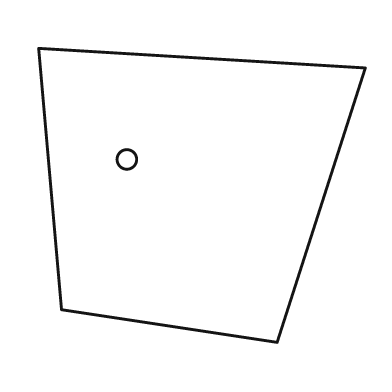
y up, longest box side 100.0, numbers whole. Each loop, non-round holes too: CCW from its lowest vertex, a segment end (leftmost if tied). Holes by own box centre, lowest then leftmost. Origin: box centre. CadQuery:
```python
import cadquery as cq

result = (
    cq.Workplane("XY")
    .moveTo(23.0, -45.0)
    .lineTo(50.0, 39.0)
    .lineTo(-50.0, 45.0)
    .lineTo(-43.0, -35.0)
    .close()
    .moveTo(-23.0, 11.0)
    .circle(3.0)
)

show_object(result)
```